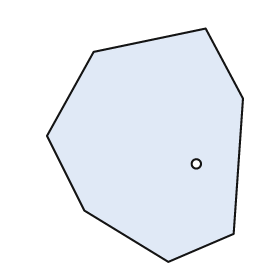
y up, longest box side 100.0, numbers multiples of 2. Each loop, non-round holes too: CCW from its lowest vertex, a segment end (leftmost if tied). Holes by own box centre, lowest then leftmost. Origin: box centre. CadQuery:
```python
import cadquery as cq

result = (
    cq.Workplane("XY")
    .moveTo(10.0, -50.0)
    .lineTo(38.0, -38.0)
    .lineTo(42.0, 20.0)
    .lineTo(26.0, 50.0)
    .lineTo(-22.0, 40.0)
    .lineTo(-42.0, 4.0)
    .lineTo(-26.0, -28.0)
    .close()
    .moveTo(22.0, -8.0)
    .circle(2.0)
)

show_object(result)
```